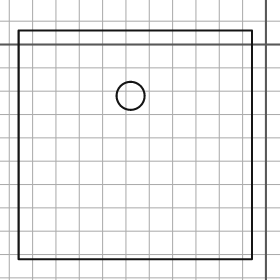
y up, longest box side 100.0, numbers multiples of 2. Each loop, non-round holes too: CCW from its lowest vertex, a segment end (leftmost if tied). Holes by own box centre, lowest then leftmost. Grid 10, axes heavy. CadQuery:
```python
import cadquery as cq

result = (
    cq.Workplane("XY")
    .moveTo(-106.0, -92.0)
    .lineTo(-6.0, -92.0)
    .lineTo(-6.0, 6.0)
    .lineTo(-106.0, 6.0)
    .close()
    .moveTo(-58.0, -22.0)
    .circle(6.0)
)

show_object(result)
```